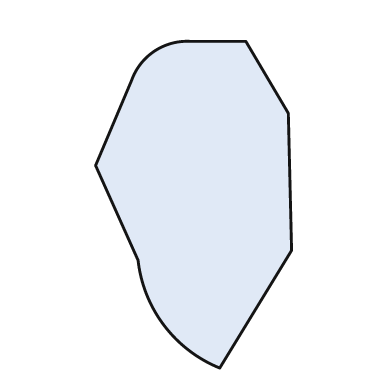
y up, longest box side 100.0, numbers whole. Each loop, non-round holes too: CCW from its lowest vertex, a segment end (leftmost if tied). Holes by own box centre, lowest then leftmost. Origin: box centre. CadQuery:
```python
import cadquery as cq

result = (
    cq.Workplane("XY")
    .moveTo(8.0, -50.0)
    .lineTo(30.0, -14.0)
    .lineTo(29.0, 28.0)
    .lineTo(16.0, 50.0)
    .lineTo(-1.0, 50.0)
    .threePointArc((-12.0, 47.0), (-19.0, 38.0))
    .lineTo(-30.0, 12.0)
    .lineTo(-17.0, -17.0)
    .threePointArc((-9.0, -37.0), (8.0, -50.0))
    .close()
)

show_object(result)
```